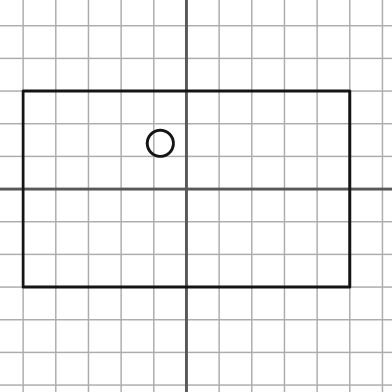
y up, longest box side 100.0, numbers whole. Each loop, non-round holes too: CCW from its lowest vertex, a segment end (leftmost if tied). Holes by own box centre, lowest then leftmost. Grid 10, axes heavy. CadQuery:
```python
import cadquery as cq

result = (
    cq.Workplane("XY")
    .moveTo(-50.0, -30.0)
    .lineTo(50.0, -30.0)
    .lineTo(50.0, 30.0)
    .lineTo(-50.0, 30.0)
    .close()
    .moveTo(-8.0, 14.0)
    .circle(4.0)
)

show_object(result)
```